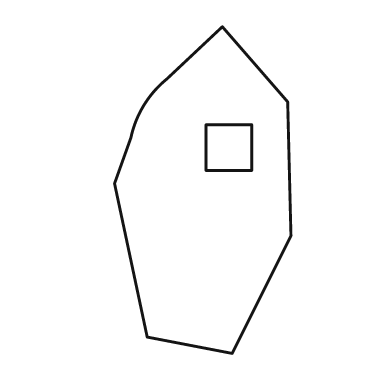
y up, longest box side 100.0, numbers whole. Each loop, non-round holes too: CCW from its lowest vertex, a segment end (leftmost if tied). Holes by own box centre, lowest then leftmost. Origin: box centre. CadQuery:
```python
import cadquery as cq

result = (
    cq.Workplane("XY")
    .moveTo(9.0, -50.0)
    .lineTo(27.0, -14.0)
    .lineTo(26.0, 27.0)
    .lineTo(6.0, 50.0)
    .lineTo(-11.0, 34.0)
    .threePointArc((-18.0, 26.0), (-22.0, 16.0))
    .lineTo(-27.0, 2.0)
    .lineTo(-17.0, -45.0)
    .close()
    .moveTo(1.0, 6.0)
    .lineTo(15.0, 6.0)
    .lineTo(15.0, 20.0)
    .lineTo(1.0, 20.0)
    .close()
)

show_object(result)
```